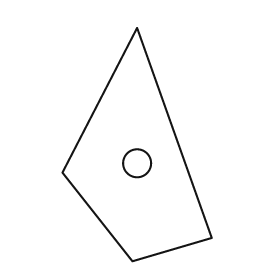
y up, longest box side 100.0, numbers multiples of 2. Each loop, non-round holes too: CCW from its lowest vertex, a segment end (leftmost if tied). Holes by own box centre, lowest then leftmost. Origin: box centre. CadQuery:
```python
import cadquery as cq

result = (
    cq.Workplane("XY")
    .moveTo(-2.0, -50.0)
    .lineTo(32.0, -40.0)
    .lineTo(0.0, 50.0)
    .lineTo(-32.0, -12.0)
    .close()
    .moveTo(0.0, -8.0)
    .circle(6.0)
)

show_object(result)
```